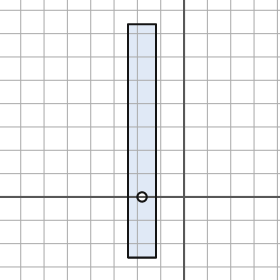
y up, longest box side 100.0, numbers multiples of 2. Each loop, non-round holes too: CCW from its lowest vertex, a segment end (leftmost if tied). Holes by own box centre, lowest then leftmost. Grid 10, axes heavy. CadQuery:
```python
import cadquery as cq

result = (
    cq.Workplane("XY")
    .moveTo(-24.0, -26.0)
    .lineTo(-12.0, -26.0)
    .lineTo(-12.0, 74.0)
    .lineTo(-24.0, 74.0)
    .close()
    .moveTo(-18.0, 0.0)
    .circle(2.0)
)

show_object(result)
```